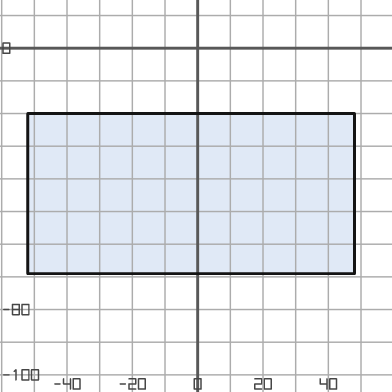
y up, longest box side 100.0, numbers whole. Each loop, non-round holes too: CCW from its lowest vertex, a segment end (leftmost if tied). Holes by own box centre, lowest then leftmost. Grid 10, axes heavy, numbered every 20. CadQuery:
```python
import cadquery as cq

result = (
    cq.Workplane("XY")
    .moveTo(-52.0, -69.0)
    .lineTo(48.0, -69.0)
    .lineTo(48.0, -20.0)
    .lineTo(-52.0, -20.0)
    .close()
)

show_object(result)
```